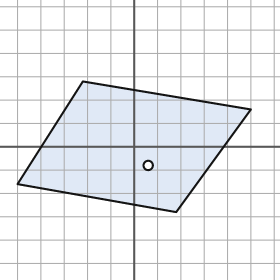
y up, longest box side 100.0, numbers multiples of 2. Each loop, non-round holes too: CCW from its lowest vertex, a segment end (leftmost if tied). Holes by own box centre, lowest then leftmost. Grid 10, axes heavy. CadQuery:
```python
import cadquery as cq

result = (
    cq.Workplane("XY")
    .moveTo(18.0, -28.0)
    .lineTo(50.0, 16.0)
    .lineTo(-22.0, 28.0)
    .lineTo(-50.0, -16.0)
    .close()
    .moveTo(6.0, -8.0)
    .circle(2.0)
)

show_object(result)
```